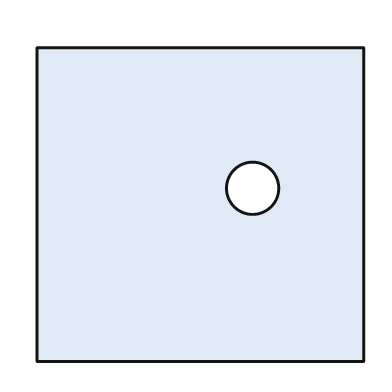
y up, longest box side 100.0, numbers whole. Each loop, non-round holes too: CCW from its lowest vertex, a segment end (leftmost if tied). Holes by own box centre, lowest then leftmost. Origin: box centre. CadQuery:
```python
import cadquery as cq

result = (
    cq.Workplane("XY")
    .moveTo(-50.0, -48.0)
    .lineTo(50.0, -48.0)
    .lineTo(50.0, 48.0)
    .lineTo(-50.0, 48.0)
    .close()
    .moveTo(16.0, 5.0)
    .circle(8.0)
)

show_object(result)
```